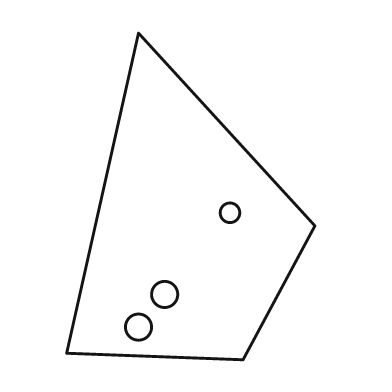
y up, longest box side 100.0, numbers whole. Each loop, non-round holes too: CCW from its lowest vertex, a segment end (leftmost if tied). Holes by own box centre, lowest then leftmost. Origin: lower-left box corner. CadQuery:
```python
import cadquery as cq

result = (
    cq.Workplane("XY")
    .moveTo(54.0, 0.0)
    .lineTo(76.0, 41.0)
    .lineTo(22.0, 100.0)
    .lineTo(0.0, 2.0)
    .close()
    .moveTo(22.0, 10.0)
    .circle(4.0)
    .moveTo(30.0, 20.0)
    .circle(4.0)
    .moveTo(50.0, 45.0)
    .circle(3.0)
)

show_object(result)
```